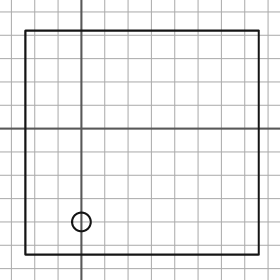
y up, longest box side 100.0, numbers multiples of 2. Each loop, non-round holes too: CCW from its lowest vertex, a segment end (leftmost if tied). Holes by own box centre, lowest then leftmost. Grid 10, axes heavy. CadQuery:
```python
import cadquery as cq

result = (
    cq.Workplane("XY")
    .moveTo(-24.0, -54.0)
    .lineTo(76.0, -54.0)
    .lineTo(76.0, 42.0)
    .lineTo(-24.0, 42.0)
    .close()
    .moveTo(0.0, -40.0)
    .circle(4.0)
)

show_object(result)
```